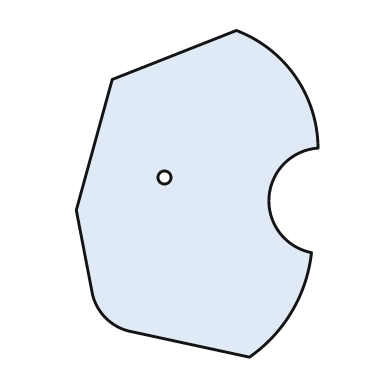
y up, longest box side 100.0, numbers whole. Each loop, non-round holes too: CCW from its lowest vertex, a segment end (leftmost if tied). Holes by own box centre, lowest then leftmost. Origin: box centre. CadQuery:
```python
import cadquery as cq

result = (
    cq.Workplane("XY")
    .moveTo(16.0, -50.0)
    .threePointArc((29.0, -36.0), (35.0, -18.0))
    .threePointArc((22.0, -1.0), (37.0, 14.0))
    .threePointArc((30.0, 36.0), (12.0, 50.0))
    .lineTo(-26.0, 35.0)
    .lineTo(-37.0, -5.0)
    .lineTo(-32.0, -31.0)
    .threePointArc((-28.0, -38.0), (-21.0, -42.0))
    .close()
    .moveTo(-10.0, 5.0)
    .circle(2.0)
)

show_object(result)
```